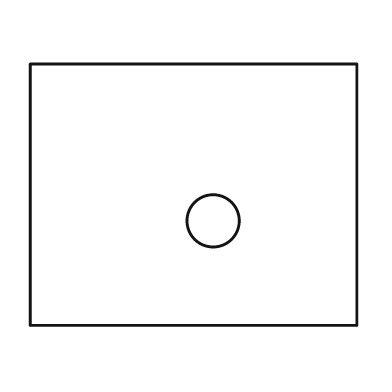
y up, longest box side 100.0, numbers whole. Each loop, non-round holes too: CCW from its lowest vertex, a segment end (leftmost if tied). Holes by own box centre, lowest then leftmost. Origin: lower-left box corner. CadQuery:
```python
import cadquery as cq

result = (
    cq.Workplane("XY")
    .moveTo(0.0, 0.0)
    .lineTo(100.0, 0.0)
    .lineTo(100.0, 80.0)
    .lineTo(0.0, 80.0)
    .close()
    .moveTo(56.0, 32.0)
    .circle(8.0)
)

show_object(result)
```